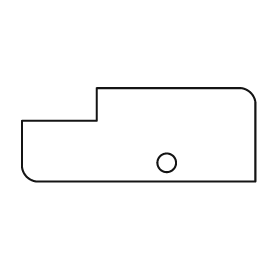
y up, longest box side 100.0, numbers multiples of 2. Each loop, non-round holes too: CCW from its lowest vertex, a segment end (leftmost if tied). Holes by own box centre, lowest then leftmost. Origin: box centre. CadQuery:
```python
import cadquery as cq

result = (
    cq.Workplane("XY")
    .moveTo(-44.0, -20.0)
    .lineTo(50.0, -20.0)
    .lineTo(50.0, 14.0)
    .threePointArc((48.0, 18.0), (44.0, 20.0))
    .lineTo(-18.0, 20.0)
    .lineTo(-18.0, 6.0)
    .lineTo(-50.0, 6.0)
    .lineTo(-50.0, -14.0)
    .threePointArc((-48.0, -18.0), (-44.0, -20.0))
    .close()
    .moveTo(12.0, -12.0)
    .circle(4.0)
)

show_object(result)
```